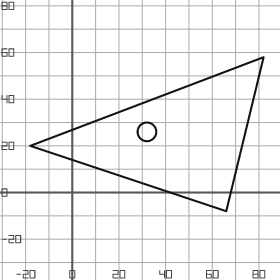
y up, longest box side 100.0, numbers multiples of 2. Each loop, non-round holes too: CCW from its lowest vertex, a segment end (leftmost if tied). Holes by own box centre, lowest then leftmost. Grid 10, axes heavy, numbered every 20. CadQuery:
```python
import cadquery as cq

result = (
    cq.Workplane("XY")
    .moveTo(66.0, -8.0)
    .lineTo(82.0, 58.0)
    .lineTo(-18.0, 20.0)
    .close()
    .moveTo(32.0, 26.0)
    .circle(4.0)
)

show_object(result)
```